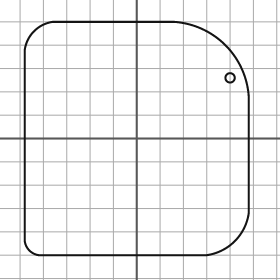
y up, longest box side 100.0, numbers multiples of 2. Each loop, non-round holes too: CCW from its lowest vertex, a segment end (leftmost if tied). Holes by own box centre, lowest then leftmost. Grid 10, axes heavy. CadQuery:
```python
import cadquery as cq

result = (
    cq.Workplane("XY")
    .moveTo(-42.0, -50.0)
    .lineTo(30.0, -50.0)
    .threePointArc((42.0, -44.0), (48.0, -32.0))
    .lineTo(48.0, 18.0)
    .threePointArc((38.0, 40.0), (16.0, 50.0))
    .lineTo(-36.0, 50.0)
    .threePointArc((-44.0, 46.0), (-48.0, 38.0))
    .lineTo(-48.0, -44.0)
    .threePointArc((-46.0, -48.0), (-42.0, -50.0))
    .close()
    .moveTo(40.0, 26.0)
    .circle(2.0)
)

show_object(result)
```